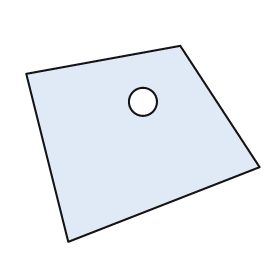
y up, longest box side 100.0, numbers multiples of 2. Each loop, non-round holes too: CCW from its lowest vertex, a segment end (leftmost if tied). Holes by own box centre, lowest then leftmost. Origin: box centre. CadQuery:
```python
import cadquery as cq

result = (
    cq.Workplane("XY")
    .moveTo(-32.0, -42.0)
    .lineTo(50.0, -10.0)
    .lineTo(16.0, 42.0)
    .lineTo(-50.0, 30.0)
    .close()
    .moveTo(0.0, 18.0)
    .circle(6.0)
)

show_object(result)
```